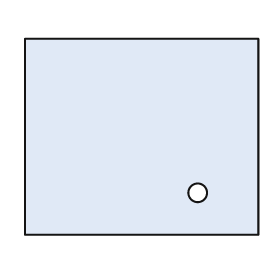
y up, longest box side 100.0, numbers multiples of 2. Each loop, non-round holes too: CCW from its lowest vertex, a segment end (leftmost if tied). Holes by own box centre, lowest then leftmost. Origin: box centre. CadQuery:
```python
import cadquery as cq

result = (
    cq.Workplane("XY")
    .moveTo(-50.0, -42.0)
    .lineTo(50.0, -42.0)
    .lineTo(50.0, 42.0)
    .lineTo(-50.0, 42.0)
    .close()
    .moveTo(24.0, -24.0)
    .circle(4.0)
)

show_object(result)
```